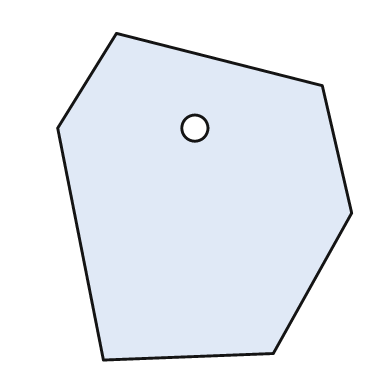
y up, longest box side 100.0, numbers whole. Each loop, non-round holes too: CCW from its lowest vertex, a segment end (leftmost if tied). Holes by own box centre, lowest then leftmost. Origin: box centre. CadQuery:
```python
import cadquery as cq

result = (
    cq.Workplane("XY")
    .moveTo(-31.0, -50.0)
    .lineTo(21.0, -48.0)
    .lineTo(45.0, -5.0)
    .lineTo(36.0, 34.0)
    .lineTo(-27.0, 50.0)
    .lineTo(-45.0, 21.0)
    .close()
    .moveTo(-3.0, 21.0)
    .circle(4.0)
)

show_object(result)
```